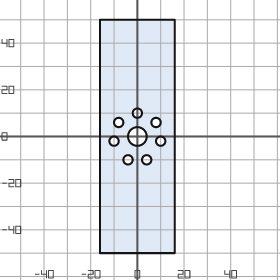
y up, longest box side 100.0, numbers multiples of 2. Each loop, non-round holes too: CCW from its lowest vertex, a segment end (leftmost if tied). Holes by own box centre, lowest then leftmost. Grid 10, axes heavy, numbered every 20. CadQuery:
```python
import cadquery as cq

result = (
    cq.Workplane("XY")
    .moveTo(-16.0, -50.0)
    .lineTo(16.0, -50.0)
    .lineTo(16.0, 50.0)
    .lineTo(-16.0, 50.0)
    .close()
    .moveTo(-4.0, -10.0)
    .circle(2.0)
    .moveTo(4.0, -10.0)
    .circle(2.0)
    .moveTo(-10.0, -2.0)
    .circle(2.0)
    .moveTo(10.0, -2.0)
    .circle(2.0)
    .moveTo(0.0, 0.0)
    .circle(4.0)
    .moveTo(-8.0, 6.0)
    .circle(2.0)
    .moveTo(8.0, 6.0)
    .circle(2.0)
    .moveTo(0.0, 10.0)
    .circle(2.0)
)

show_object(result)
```